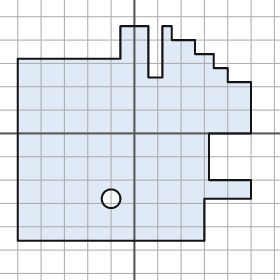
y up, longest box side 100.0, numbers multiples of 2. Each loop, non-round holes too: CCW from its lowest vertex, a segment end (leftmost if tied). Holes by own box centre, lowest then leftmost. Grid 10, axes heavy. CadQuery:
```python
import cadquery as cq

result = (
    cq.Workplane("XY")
    .moveTo(-50.0, -46.0)
    .lineTo(30.0, -46.0)
    .lineTo(30.0, -28.0)
    .lineTo(50.0, -28.0)
    .lineTo(50.0, -20.0)
    .lineTo(32.0, -20.0)
    .lineTo(32.0, 0.0)
    .lineTo(50.0, 0.0)
    .lineTo(50.0, 22.0)
    .lineTo(40.0, 22.0)
    .lineTo(40.0, 28.0)
    .lineTo(34.0, 28.0)
    .lineTo(34.0, 34.0)
    .lineTo(26.0, 34.0)
    .lineTo(26.0, 40.0)
    .lineTo(16.0, 40.0)
    .lineTo(16.0, 46.0)
    .lineTo(12.0, 46.0)
    .lineTo(12.0, 24.0)
    .lineTo(6.0, 24.0)
    .lineTo(6.0, 46.0)
    .lineTo(-6.0, 46.0)
    .lineTo(-6.0, 32.0)
    .lineTo(-50.0, 32.0)
    .close()
    .moveTo(-10.0, -28.0)
    .circle(4.0)
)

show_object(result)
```